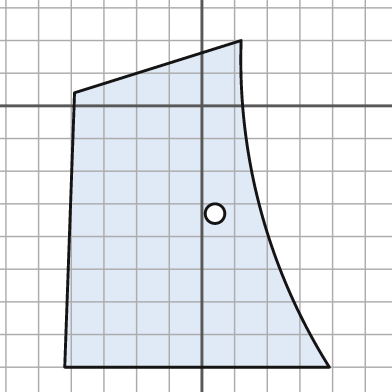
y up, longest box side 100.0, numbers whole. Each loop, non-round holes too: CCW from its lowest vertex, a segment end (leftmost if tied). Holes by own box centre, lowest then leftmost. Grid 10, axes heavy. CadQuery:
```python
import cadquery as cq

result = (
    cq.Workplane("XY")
    .moveTo(-42.0, -80.0)
    .lineTo(39.0, -80.0)
    .threePointArc((18.0, -32.0), (12.0, 20.0))
    .lineTo(-39.0, 4.0)
    .close()
    .moveTo(4.0, -33.0)
    .circle(3.0)
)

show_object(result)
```